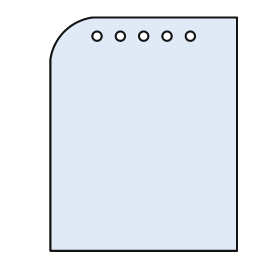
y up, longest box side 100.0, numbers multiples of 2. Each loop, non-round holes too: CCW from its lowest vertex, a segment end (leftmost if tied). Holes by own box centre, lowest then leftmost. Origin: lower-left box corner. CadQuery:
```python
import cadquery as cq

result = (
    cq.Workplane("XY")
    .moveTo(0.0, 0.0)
    .lineTo(80.0, 0.0)
    .lineTo(80.0, 100.0)
    .lineTo(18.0, 100.0)
    .threePointArc((6.0, 94.0), (0.0, 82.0))
    .close()
    .moveTo(20.0, 92.0)
    .circle(2.0)
    .moveTo(30.0, 92.0)
    .circle(2.0)
    .moveTo(40.0, 92.0)
    .circle(2.0)
    .moveTo(50.0, 92.0)
    .circle(2.0)
    .moveTo(60.0, 92.0)
    .circle(2.0)
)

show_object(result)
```